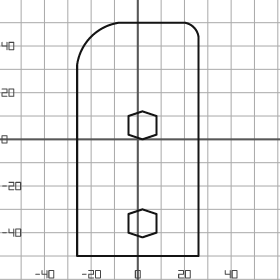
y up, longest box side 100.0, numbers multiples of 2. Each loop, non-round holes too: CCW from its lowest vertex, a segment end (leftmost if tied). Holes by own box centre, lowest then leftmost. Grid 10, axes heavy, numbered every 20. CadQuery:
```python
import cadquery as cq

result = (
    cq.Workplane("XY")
    .moveTo(-26.0, -50.0)
    .lineTo(26.0, -50.0)
    .lineTo(26.0, 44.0)
    .threePointArc((24.0, 48.0), (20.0, 50.0))
    .lineTo(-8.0, 50.0)
    .threePointArc((-20.0, 44.0), (-26.0, 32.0))
    .close()
    .moveTo(2.0, -42.0)
    .lineTo(8.0, -40.0)
    .lineTo(8.0, -32.0)
    .lineTo(2.0, -30.0)
    .lineTo(-4.0, -32.0)
    .lineTo(-4.0, -40.0)
    .close()
    .moveTo(2.0, 0.0)
    .lineTo(8.0, 2.0)
    .lineTo(8.0, 10.0)
    .lineTo(2.0, 12.0)
    .lineTo(-4.0, 10.0)
    .lineTo(-4.0, 2.0)
    .close()
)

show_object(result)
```